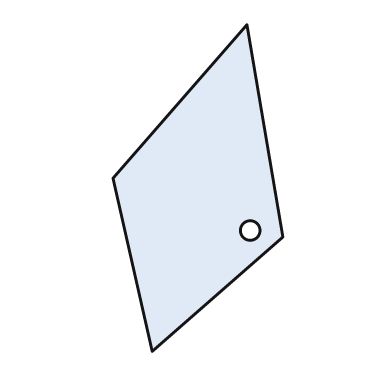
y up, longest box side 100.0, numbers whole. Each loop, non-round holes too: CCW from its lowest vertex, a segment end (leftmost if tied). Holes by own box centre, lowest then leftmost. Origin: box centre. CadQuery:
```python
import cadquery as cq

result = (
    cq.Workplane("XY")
    .moveTo(-14.0, -50.0)
    .lineTo(26.0, -15.0)
    .lineTo(15.0, 50.0)
    .lineTo(-26.0, 3.0)
    .close()
    .moveTo(16.0, -13.0)
    .circle(3.0)
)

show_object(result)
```